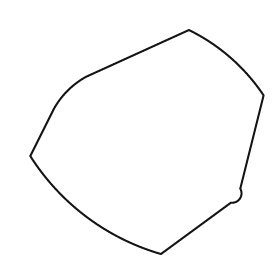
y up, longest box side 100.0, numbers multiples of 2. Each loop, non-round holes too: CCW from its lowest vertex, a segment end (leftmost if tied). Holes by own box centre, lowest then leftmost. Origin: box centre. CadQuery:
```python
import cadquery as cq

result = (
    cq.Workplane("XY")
    .moveTo(6.0, -48.0)
    .lineTo(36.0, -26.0)
    .threePointArc((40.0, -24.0), (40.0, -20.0))
    .lineTo(50.0, 20.0)
    .threePointArc((36.0, 36.0), (18.0, 48.0))
    .lineTo(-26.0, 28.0)
    .threePointArc((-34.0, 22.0), (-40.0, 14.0))
    .lineTo(-50.0, -6.0)
    .threePointArc((-26.0, -32.0), (6.0, -48.0))
    .close()
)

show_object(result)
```